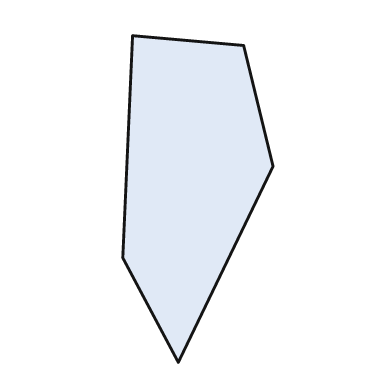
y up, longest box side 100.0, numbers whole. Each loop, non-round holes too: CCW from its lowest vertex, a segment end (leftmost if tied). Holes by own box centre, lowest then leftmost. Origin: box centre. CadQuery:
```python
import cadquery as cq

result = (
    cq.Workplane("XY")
    .moveTo(-6.0, -50.0)
    .lineTo(23.0, 10.0)
    .lineTo(14.0, 47.0)
    .lineTo(-20.0, 50.0)
    .lineTo(-23.0, -18.0)
    .close()
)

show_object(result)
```